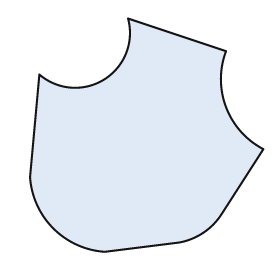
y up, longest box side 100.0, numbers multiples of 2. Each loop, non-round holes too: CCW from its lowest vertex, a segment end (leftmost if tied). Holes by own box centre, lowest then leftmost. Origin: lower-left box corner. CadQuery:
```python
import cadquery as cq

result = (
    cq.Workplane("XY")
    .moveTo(32.0, 0.0)
    .lineTo(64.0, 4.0)
    .threePointArc((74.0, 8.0), (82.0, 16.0))
    .lineTo(100.0, 44.0)
    .threePointArc((84.0, 62.0), (84.0, 86.0))
    .lineTo(42.0, 100.0)
    .threePointArc((32.0, 74.0), (4.0, 76.0))
    .lineTo(0.0, 32.0)
    .threePointArc((10.0, 10.0), (32.0, 0.0))
    .close()
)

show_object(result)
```